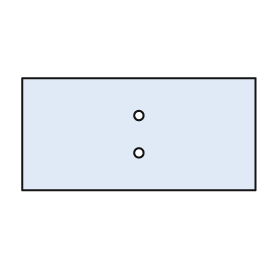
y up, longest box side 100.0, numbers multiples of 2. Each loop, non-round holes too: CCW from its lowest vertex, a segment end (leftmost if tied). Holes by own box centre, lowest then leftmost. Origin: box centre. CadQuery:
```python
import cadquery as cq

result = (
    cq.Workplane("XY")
    .moveTo(-50.0, -24.0)
    .lineTo(50.0, -24.0)
    .lineTo(50.0, 24.0)
    .lineTo(-50.0, 24.0)
    .close()
    .moveTo(0.0, -8.0)
    .circle(2.0)
    .moveTo(0.0, 8.0)
    .circle(2.0)
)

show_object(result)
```